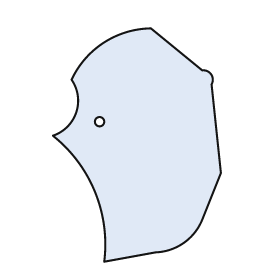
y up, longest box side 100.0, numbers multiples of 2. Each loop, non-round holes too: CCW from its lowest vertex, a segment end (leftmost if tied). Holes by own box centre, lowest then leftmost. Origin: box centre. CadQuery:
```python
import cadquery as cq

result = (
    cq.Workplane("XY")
    .moveTo(-14.0, -50.0)
    .lineTo(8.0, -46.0)
    .threePointArc((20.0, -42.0), (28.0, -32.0))
    .lineTo(36.0, -12.0)
    .lineTo(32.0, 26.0)
    .threePointArc((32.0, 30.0), (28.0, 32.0))
    .lineTo(6.0, 50.0)
    .threePointArc((-14.0, 44.0), (-28.0, 28.0))
    .threePointArc((-26.0, 14.0), (-36.0, 4.0))
    .threePointArc((-18.0, -20.0), (-14.0, -50.0))
    .close()
    .moveTo(-16.0, 10.0)
    .circle(2.0)
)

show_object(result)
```